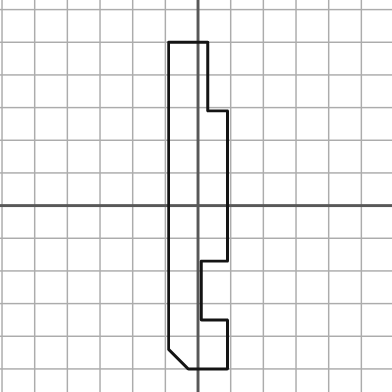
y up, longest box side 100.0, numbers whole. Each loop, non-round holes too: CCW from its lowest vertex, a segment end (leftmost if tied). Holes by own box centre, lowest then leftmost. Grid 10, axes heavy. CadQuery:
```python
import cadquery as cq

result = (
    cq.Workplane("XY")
    .moveTo(-3.0, -50.0)
    .lineTo(9.0, -50.0)
    .lineTo(9.0, -35.0)
    .lineTo(1.0, -35.0)
    .lineTo(1.0, -17.0)
    .lineTo(9.0, -17.0)
    .lineTo(9.0, 29.0)
    .lineTo(3.0, 29.0)
    .lineTo(3.0, 50.0)
    .lineTo(-9.0, 50.0)
    .lineTo(-9.0, -44.0)
    .close()
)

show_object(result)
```